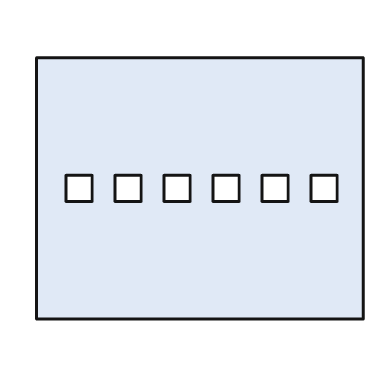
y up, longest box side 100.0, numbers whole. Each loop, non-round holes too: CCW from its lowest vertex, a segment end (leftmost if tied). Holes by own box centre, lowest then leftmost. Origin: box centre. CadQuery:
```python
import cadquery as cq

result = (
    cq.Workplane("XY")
    .moveTo(-50.0, -40.0)
    .lineTo(50.0, -40.0)
    .lineTo(50.0, 40.0)
    .lineTo(-50.0, 40.0)
    .close()
    .moveTo(-41.0, -4.0)
    .lineTo(-33.0, -4.0)
    .lineTo(-33.0, 4.0)
    .lineTo(-41.0, 4.0)
    .close()
    .moveTo(-26.0, -4.0)
    .lineTo(-18.0, -4.0)
    .lineTo(-18.0, 4.0)
    .lineTo(-26.0, 4.0)
    .close()
    .moveTo(-11.0, -4.0)
    .lineTo(-3.0, -4.0)
    .lineTo(-3.0, 4.0)
    .lineTo(-11.0, 4.0)
    .close()
    .moveTo(4.0, -4.0)
    .lineTo(12.0, -4.0)
    .lineTo(12.0, 4.0)
    .lineTo(4.0, 4.0)
    .close()
    .moveTo(19.0, -4.0)
    .lineTo(27.0, -4.0)
    .lineTo(27.0, 4.0)
    .lineTo(19.0, 4.0)
    .close()
    .moveTo(34.0, -4.0)
    .lineTo(42.0, -4.0)
    .lineTo(42.0, 4.0)
    .lineTo(34.0, 4.0)
    .close()
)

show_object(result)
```